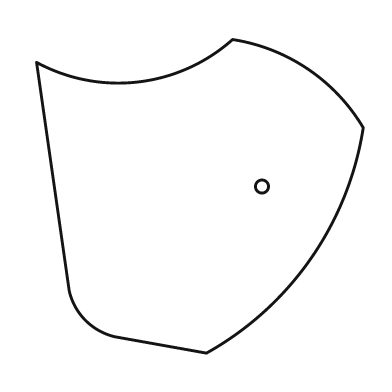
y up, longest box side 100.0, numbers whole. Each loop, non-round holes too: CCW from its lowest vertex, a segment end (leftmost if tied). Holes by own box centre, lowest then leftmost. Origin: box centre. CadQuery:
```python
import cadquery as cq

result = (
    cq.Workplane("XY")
    .moveTo(2.0, -48.0)
    .threePointArc((34.0, -19.0), (50.0, 21.0))
    .threePointArc((33.0, 39.0), (10.0, 48.0))
    .threePointArc((-19.0, 35.0), (-50.0, 41.0))
    .lineTo(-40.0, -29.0)
    .threePointArc((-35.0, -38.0), (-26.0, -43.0))
    .close()
    .moveTo(19.0, 3.0)
    .circle(2.0)
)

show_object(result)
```